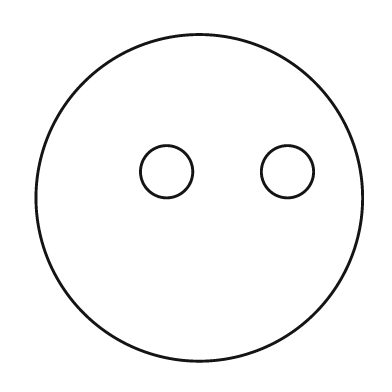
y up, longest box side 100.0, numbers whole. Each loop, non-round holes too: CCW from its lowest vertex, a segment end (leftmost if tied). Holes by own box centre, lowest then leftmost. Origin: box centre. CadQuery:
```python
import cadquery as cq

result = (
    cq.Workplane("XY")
    .moveTo(0.0, 0.0)
    .circle(50.0)
    .moveTo(-10.0, 8.0)
    .circle(8.0)
    .moveTo(27.0, 8.0)
    .circle(8.0)
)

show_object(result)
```